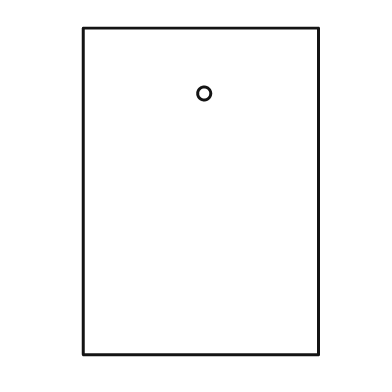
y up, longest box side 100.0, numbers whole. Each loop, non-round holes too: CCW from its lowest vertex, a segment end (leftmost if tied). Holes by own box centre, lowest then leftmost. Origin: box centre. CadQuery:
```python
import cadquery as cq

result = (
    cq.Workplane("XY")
    .moveTo(-36.0, -50.0)
    .lineTo(36.0, -50.0)
    .lineTo(36.0, 50.0)
    .lineTo(-36.0, 50.0)
    .close()
    .moveTo(1.0, 30.0)
    .circle(2.0)
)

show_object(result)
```